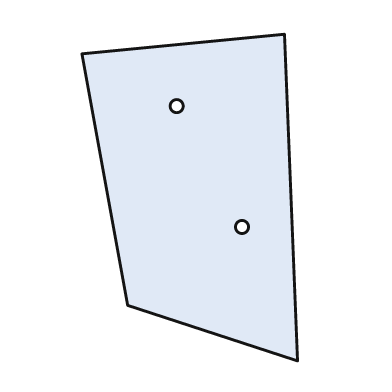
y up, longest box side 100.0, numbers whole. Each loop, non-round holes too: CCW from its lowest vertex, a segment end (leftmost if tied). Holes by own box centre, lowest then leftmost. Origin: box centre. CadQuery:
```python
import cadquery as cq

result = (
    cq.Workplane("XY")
    .moveTo(33.0, -50.0)
    .lineTo(29.0, 50.0)
    .lineTo(-33.0, 44.0)
    .lineTo(-19.0, -33.0)
    .close()
    .moveTo(16.0, -9.0)
    .circle(2.0)
    .moveTo(-4.0, 28.0)
    .circle(2.0)
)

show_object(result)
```